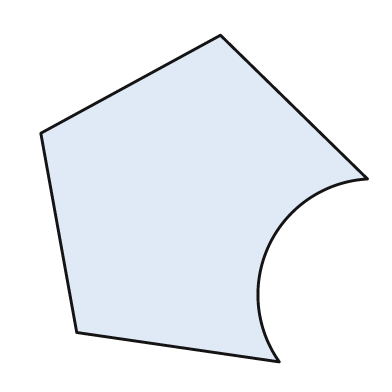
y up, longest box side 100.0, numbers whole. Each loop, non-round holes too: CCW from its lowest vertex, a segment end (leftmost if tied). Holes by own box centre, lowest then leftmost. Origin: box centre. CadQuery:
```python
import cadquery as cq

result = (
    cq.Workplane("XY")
    .moveTo(23.0, -50.0)
    .threePointArc((20.0, -14.0), (50.0, 6.0))
    .lineTo(5.0, 50.0)
    .lineTo(-50.0, 20.0)
    .lineTo(-39.0, -41.0)
    .close()
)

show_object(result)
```